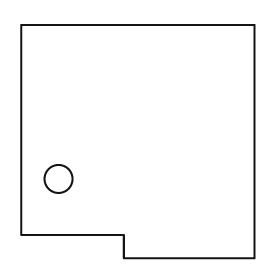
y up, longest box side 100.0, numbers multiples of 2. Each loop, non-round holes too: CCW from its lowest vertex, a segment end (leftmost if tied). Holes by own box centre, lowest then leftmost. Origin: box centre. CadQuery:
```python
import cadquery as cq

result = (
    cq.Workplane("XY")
    .moveTo(-6.0, -50.0)
    .lineTo(50.0, -50.0)
    .lineTo(50.0, 50.0)
    .lineTo(-50.0, 50.0)
    .lineTo(-50.0, -40.0)
    .lineTo(-6.0, -40.0)
    .close()
    .moveTo(-34.0, -16.0)
    .circle(6.0)
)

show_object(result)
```